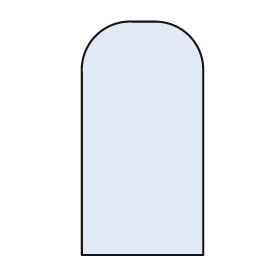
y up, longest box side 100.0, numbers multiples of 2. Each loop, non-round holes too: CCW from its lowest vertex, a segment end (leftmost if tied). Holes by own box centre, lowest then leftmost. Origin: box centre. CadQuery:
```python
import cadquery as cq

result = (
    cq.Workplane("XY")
    .moveTo(-26.0, -50.0)
    .lineTo(26.0, -50.0)
    .lineTo(26.0, 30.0)
    .threePointArc((20.0, 44.0), (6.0, 50.0))
    .lineTo(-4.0, 50.0)
    .threePointArc((-20.0, 44.0), (-26.0, 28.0))
    .close()
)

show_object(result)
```